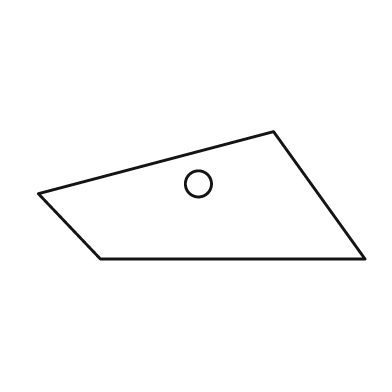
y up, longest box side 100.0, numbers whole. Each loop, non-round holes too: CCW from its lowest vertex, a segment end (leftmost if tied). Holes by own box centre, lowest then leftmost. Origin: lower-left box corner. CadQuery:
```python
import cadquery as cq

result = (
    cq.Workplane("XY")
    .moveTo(19.0, 0.0)
    .lineTo(100.0, 0.0)
    .lineTo(72.0, 39.0)
    .lineTo(0.0, 20.0)
    .close()
    .moveTo(49.0, 23.0)
    .circle(4.0)
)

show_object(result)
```